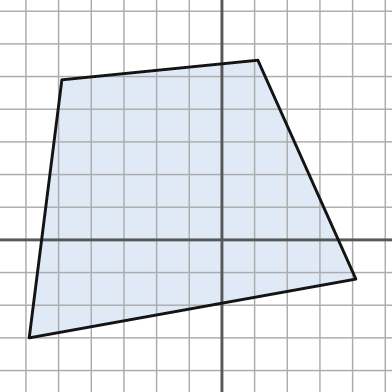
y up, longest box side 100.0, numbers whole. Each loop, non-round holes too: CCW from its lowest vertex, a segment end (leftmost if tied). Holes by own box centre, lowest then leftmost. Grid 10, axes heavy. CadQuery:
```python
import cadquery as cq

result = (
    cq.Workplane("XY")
    .moveTo(-59.0, -30.0)
    .lineTo(41.0, -12.0)
    .lineTo(11.0, 55.0)
    .lineTo(-49.0, 49.0)
    .close()
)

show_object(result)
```